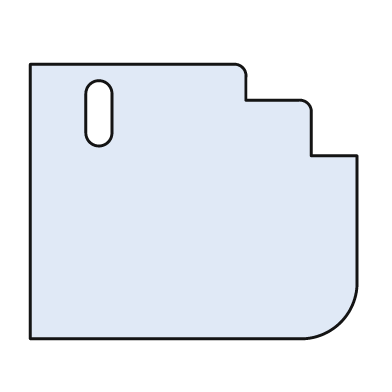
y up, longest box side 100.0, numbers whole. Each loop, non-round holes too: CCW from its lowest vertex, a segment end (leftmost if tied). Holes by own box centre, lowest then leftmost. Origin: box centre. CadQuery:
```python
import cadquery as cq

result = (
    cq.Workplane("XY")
    .moveTo(-50.0, -42.0)
    .lineTo(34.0, -42.0)
    .threePointArc((45.0, -37.0), (50.0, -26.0))
    .lineTo(50.0, 14.0)
    .lineTo(36.0, 14.0)
    .lineTo(36.0, 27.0)
    .threePointArc((35.0, 30.0), (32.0, 31.0))
    .lineTo(16.0, 31.0)
    .lineTo(16.0, 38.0)
    .threePointArc((15.0, 41.0), (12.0, 42.0))
    .lineTo(-50.0, 42.0)
    .close()
    .moveTo(-33.0, 21.0)
    .threePointArc((-29.0, 17.0), (-25.0, 21.0))
    .lineTo(-25.0, 33.0)
    .threePointArc((-29.0, 37.0), (-33.0, 33.0))
    .close()
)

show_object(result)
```